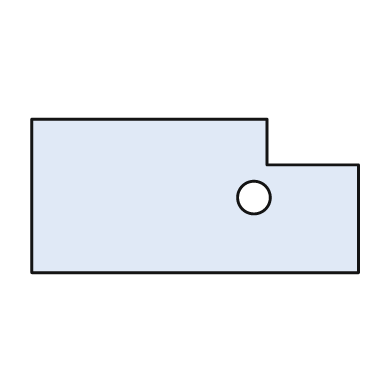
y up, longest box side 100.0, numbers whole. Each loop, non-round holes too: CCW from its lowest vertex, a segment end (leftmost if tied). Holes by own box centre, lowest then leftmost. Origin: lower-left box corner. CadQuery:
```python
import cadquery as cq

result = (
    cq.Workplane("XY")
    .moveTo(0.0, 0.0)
    .lineTo(100.0, 0.0)
    .lineTo(100.0, 33.0)
    .lineTo(72.0, 33.0)
    .lineTo(72.0, 47.0)
    .lineTo(0.0, 47.0)
    .close()
    .moveTo(68.0, 23.0)
    .circle(5.0)
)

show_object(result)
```